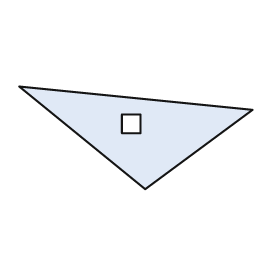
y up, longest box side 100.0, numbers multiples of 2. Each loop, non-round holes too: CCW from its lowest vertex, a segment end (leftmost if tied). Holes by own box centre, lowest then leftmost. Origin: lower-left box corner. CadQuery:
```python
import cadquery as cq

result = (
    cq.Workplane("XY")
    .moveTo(54.0, 0.0)
    .lineTo(100.0, 34.0)
    .lineTo(0.0, 44.0)
    .close()
    .moveTo(44.0, 24.0)
    .lineTo(52.0, 24.0)
    .lineTo(52.0, 32.0)
    .lineTo(44.0, 32.0)
    .close()
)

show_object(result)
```